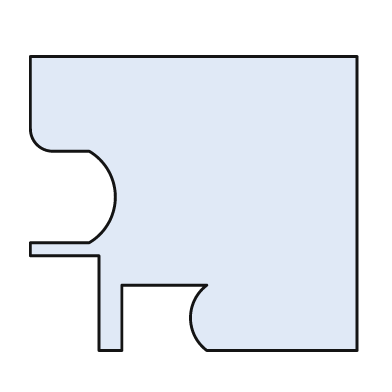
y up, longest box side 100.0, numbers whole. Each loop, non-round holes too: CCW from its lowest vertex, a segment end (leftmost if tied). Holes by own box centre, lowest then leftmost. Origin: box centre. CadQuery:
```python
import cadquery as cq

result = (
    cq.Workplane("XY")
    .moveTo(-29.0, -45.0)
    .lineTo(-22.0, -45.0)
    .lineTo(-22.0, -25.0)
    .lineTo(4.0, -25.0)
    .threePointArc((-1.0, -35.0), (4.0, -45.0))
    .lineTo(50.0, -45.0)
    .lineTo(50.0, 45.0)
    .lineTo(-50.0, 45.0)
    .lineTo(-50.0, 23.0)
    .threePointArc((-48.0, 18.0), (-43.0, 16.0))
    .lineTo(-32.0, 16.0)
    .threePointArc((-24.0, 2.0), (-32.0, -12.0))
    .lineTo(-50.0, -12.0)
    .lineTo(-50.0, -16.0)
    .lineTo(-29.0, -16.0)
    .close()
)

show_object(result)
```